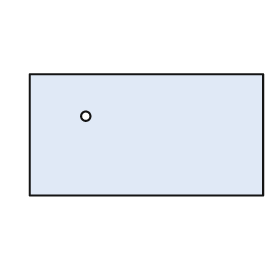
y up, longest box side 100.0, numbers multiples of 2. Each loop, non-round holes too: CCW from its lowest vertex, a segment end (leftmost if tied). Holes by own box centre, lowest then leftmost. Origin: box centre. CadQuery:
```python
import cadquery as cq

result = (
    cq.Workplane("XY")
    .moveTo(-50.0, -26.0)
    .lineTo(50.0, -26.0)
    .lineTo(50.0, 26.0)
    .lineTo(-50.0, 26.0)
    .close()
    .moveTo(-26.0, 8.0)
    .circle(2.0)
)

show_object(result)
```